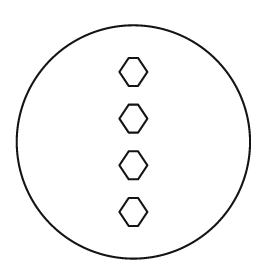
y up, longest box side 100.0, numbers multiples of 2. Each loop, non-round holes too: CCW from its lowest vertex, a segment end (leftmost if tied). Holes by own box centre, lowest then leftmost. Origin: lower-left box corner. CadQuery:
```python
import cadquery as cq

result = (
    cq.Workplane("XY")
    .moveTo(50.0, 50.0)
    .circle(50.0)
    .moveTo(48.0, 14.0)
    .lineTo(52.0, 14.0)
    .lineTo(56.0, 20.0)
    .lineTo(52.0, 26.0)
    .lineTo(48.0, 26.0)
    .lineTo(44.0, 20.0)
    .close()
    .moveTo(48.0, 34.0)
    .lineTo(52.0, 34.0)
    .lineTo(56.0, 40.0)
    .lineTo(52.0, 46.0)
    .lineTo(48.0, 46.0)
    .lineTo(44.0, 40.0)
    .close()
    .moveTo(48.0, 54.0)
    .lineTo(52.0, 54.0)
    .lineTo(56.0, 60.0)
    .lineTo(52.0, 66.0)
    .lineTo(48.0, 66.0)
    .lineTo(44.0, 60.0)
    .close()
    .moveTo(48.0, 74.0)
    .lineTo(52.0, 74.0)
    .lineTo(56.0, 80.0)
    .lineTo(52.0, 86.0)
    .lineTo(48.0, 86.0)
    .lineTo(44.0, 80.0)
    .close()
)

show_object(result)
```